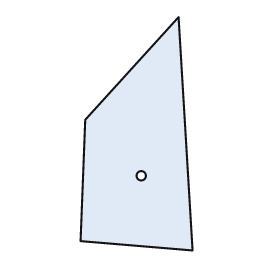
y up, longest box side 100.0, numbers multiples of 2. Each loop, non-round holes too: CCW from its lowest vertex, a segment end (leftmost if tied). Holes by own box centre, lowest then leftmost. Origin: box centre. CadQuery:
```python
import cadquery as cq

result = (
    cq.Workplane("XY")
    .moveTo(24.0, -50.0)
    .lineTo(18.0, 50.0)
    .lineTo(-22.0, 6.0)
    .lineTo(-24.0, -46.0)
    .close()
    .moveTo(2.0, -18.0)
    .circle(2.0)
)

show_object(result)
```